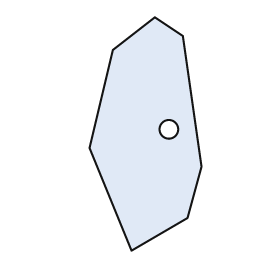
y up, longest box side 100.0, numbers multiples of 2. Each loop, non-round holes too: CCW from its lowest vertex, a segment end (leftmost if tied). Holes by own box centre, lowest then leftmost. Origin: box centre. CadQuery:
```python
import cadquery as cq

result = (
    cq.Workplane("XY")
    .moveTo(-6.0, -50.0)
    .lineTo(18.0, -36.0)
    .lineTo(24.0, -14.0)
    .lineTo(16.0, 42.0)
    .lineTo(4.0, 50.0)
    .lineTo(-14.0, 36.0)
    .lineTo(-24.0, -6.0)
    .close()
    .moveTo(10.0, 2.0)
    .circle(4.0)
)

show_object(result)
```